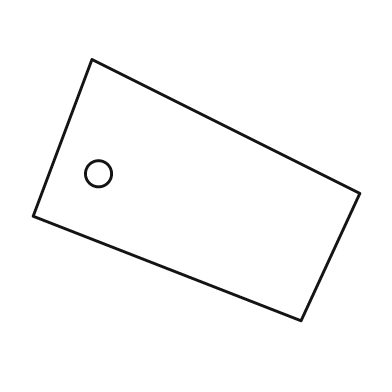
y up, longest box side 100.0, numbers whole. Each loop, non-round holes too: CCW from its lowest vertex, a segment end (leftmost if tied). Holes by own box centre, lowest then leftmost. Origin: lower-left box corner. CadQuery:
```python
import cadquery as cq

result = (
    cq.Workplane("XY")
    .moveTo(82.0, 0.0)
    .lineTo(100.0, 39.0)
    .lineTo(18.0, 80.0)
    .lineTo(0.0, 32.0)
    .close()
    .moveTo(20.0, 45.0)
    .circle(4.0)
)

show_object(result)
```